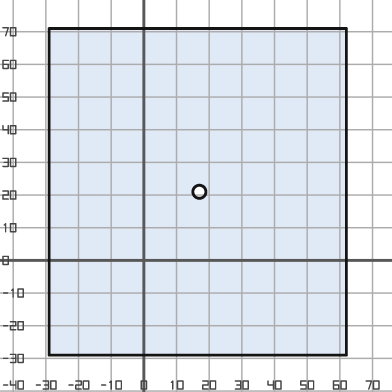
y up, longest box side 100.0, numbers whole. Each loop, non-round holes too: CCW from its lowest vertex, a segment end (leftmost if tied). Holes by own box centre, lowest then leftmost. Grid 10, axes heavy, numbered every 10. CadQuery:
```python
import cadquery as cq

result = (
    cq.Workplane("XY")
    .moveTo(-29.0, -29.0)
    .lineTo(62.0, -29.0)
    .lineTo(62.0, 71.0)
    .lineTo(-29.0, 71.0)
    .close()
    .moveTo(17.0, 21.0)
    .circle(2.0)
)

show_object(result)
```